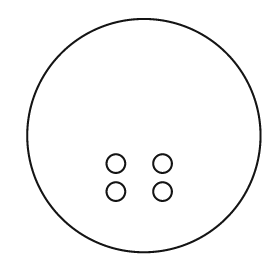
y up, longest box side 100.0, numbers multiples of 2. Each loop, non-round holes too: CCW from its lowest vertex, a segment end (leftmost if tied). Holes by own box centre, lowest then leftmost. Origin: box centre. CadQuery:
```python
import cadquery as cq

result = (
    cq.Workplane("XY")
    .moveTo(0.0, 0.0)
    .circle(50.0)
    .moveTo(-12.0, -24.0)
    .circle(4.0)
    .moveTo(8.0, -24.0)
    .circle(4.0)
    .moveTo(-12.0, -12.0)
    .circle(4.0)
    .moveTo(8.0, -12.0)
    .circle(4.0)
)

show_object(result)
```